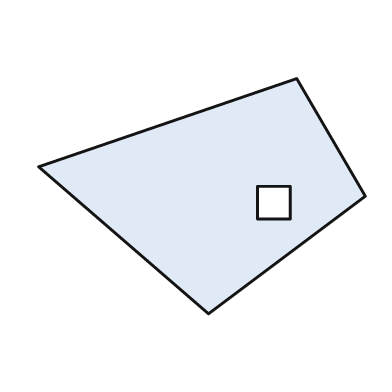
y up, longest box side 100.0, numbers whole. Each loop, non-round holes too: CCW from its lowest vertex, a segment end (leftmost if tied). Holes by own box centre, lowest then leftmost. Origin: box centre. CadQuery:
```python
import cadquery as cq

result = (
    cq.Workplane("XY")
    .moveTo(2.0, -36.0)
    .lineTo(50.0, 0.0)
    .lineTo(29.0, 36.0)
    .lineTo(-50.0, 9.0)
    .close()
    .moveTo(17.0, -7.0)
    .lineTo(27.0, -7.0)
    .lineTo(27.0, 3.0)
    .lineTo(17.0, 3.0)
    .close()
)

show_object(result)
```